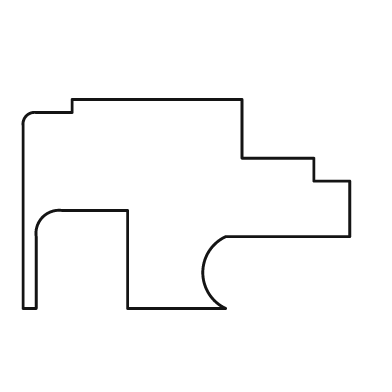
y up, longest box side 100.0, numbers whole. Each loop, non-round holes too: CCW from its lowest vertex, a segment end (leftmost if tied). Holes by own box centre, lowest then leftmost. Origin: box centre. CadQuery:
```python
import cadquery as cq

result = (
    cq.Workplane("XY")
    .moveTo(-50.0, -32.0)
    .lineTo(-46.0, -32.0)
    .lineTo(-46.0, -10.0)
    .threePointArc((-44.0, -4.0), (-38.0, -2.0))
    .lineTo(-18.0, -2.0)
    .lineTo(-18.0, -32.0)
    .lineTo(12.0, -32.0)
    .threePointArc((5.0, -21.0), (12.0, -10.0))
    .lineTo(50.0, -10.0)
    .lineTo(50.0, 7.0)
    .lineTo(39.0, 7.0)
    .lineTo(39.0, 14.0)
    .lineTo(17.0, 14.0)
    .lineTo(17.0, 32.0)
    .lineTo(-35.0, 32.0)
    .lineTo(-35.0, 28.0)
    .lineTo(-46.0, 28.0)
    .threePointArc((-49.0, 27.0), (-50.0, 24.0))
    .close()
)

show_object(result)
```